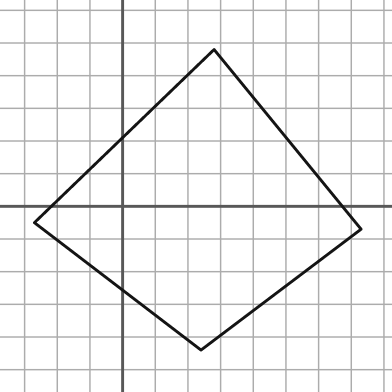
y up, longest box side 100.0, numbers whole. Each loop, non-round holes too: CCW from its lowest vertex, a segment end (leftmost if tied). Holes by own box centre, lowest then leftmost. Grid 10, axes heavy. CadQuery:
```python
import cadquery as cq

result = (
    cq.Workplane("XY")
    .moveTo(24.0, -44.0)
    .lineTo(73.0, -7.0)
    .lineTo(28.0, 48.0)
    .lineTo(-27.0, -5.0)
    .close()
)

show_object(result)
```